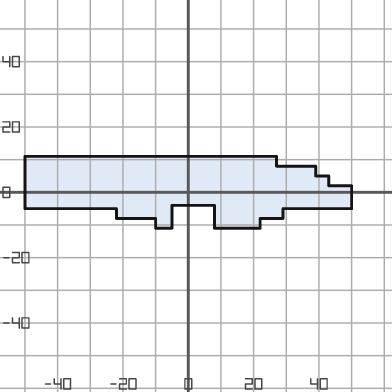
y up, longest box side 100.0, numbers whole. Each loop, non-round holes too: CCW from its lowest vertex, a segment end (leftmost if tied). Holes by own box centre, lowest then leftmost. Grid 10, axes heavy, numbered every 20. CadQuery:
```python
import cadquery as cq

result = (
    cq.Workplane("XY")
    .moveTo(-10.0, -11.0)
    .lineTo(-5.0, -11.0)
    .lineTo(-5.0, -4.0)
    .lineTo(8.0, -4.0)
    .lineTo(8.0, -11.0)
    .lineTo(22.0, -11.0)
    .lineTo(22.0, -8.0)
    .lineTo(29.0, -8.0)
    .lineTo(29.0, -5.0)
    .lineTo(50.0, -5.0)
    .lineTo(50.0, 2.0)
    .lineTo(43.0, 2.0)
    .lineTo(43.0, 5.0)
    .lineTo(39.0, 5.0)
    .lineTo(39.0, 8.0)
    .lineTo(27.0, 8.0)
    .lineTo(27.0, 11.0)
    .lineTo(-50.0, 11.0)
    .lineTo(-50.0, -5.0)
    .lineTo(-22.0, -5.0)
    .lineTo(-22.0, -8.0)
    .lineTo(-10.0, -8.0)
    .close()
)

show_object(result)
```